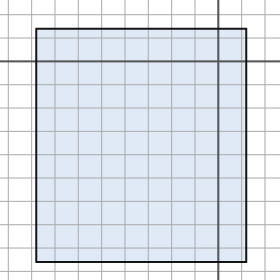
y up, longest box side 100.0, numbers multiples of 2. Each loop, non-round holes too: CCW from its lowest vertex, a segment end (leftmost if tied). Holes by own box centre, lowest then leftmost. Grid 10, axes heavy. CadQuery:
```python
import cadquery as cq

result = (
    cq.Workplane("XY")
    .moveTo(-78.0, -86.0)
    .lineTo(12.0, -86.0)
    .lineTo(12.0, 14.0)
    .lineTo(-78.0, 14.0)
    .close()
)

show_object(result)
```